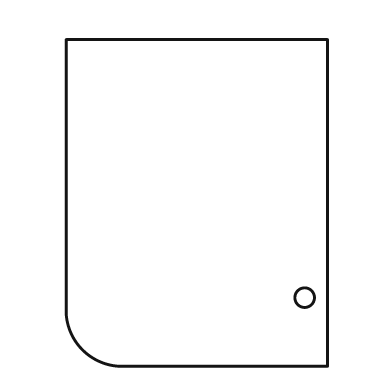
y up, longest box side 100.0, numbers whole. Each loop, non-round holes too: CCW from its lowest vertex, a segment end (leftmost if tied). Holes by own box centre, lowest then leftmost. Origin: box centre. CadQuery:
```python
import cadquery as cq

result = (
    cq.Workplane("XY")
    .moveTo(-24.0, -50.0)
    .lineTo(40.0, -50.0)
    .lineTo(40.0, 50.0)
    .lineTo(-40.0, 50.0)
    .lineTo(-40.0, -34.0)
    .threePointArc((-35.0, -45.0), (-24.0, -50.0))
    .close()
    .moveTo(33.0, -29.0)
    .circle(3.0)
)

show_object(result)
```